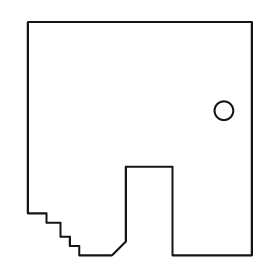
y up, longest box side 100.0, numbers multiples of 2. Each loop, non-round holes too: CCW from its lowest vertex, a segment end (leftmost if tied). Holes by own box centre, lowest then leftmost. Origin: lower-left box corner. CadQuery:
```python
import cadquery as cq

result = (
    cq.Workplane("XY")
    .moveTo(22.0, 0.0)
    .lineTo(36.0, 0.0)
    .lineTo(42.0, 6.0)
    .lineTo(42.0, 38.0)
    .lineTo(62.0, 38.0)
    .lineTo(62.0, 0.0)
    .lineTo(96.0, 0.0)
    .lineTo(96.0, 100.0)
    .lineTo(0.0, 100.0)
    .lineTo(0.0, 18.0)
    .lineTo(8.0, 18.0)
    .lineTo(8.0, 14.0)
    .lineTo(14.0, 14.0)
    .lineTo(14.0, 8.0)
    .lineTo(18.0, 8.0)
    .lineTo(18.0, 4.0)
    .lineTo(22.0, 4.0)
    .close()
    .moveTo(84.0, 62.0)
    .circle(4.0)
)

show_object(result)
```